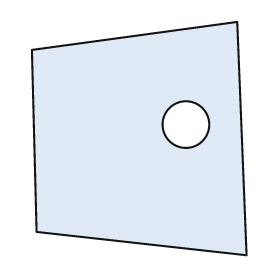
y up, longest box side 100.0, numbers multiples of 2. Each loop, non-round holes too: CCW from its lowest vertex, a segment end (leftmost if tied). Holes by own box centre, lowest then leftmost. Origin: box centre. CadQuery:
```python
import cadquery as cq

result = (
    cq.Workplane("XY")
    .moveTo(46.0, -50.0)
    .lineTo(42.0, 50.0)
    .lineTo(-46.0, 38.0)
    .lineTo(-44.0, -40.0)
    .close()
    .moveTo(20.0, 6.0)
    .circle(10.0)
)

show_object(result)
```